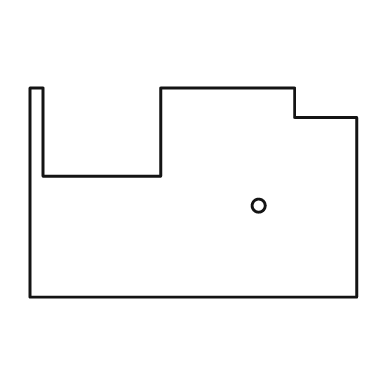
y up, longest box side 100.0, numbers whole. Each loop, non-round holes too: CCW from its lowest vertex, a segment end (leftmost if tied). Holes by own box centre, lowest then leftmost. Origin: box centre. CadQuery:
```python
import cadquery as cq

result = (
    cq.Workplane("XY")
    .moveTo(-50.0, -32.0)
    .lineTo(50.0, -32.0)
    .lineTo(50.0, 23.0)
    .lineTo(31.0, 23.0)
    .lineTo(31.0, 32.0)
    .lineTo(-10.0, 32.0)
    .lineTo(-10.0, 5.0)
    .lineTo(-46.0, 5.0)
    .lineTo(-46.0, 32.0)
    .lineTo(-50.0, 32.0)
    .close()
    .moveTo(20.0, -4.0)
    .circle(2.0)
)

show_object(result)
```